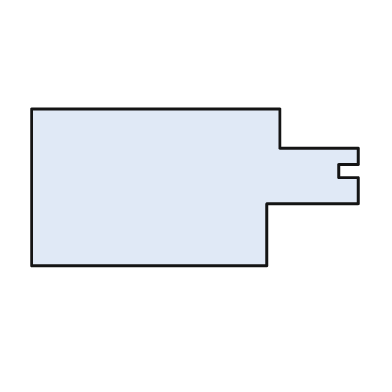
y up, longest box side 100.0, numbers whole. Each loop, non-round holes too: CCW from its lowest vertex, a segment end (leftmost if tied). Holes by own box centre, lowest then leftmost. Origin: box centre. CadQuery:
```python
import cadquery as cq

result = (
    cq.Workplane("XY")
    .moveTo(-50.0, -24.0)
    .lineTo(22.0, -24.0)
    .lineTo(22.0, -5.0)
    .lineTo(50.0, -5.0)
    .lineTo(50.0, 3.0)
    .lineTo(44.0, 3.0)
    .lineTo(44.0, 7.0)
    .lineTo(50.0, 7.0)
    .lineTo(50.0, 12.0)
    .lineTo(26.0, 12.0)
    .lineTo(26.0, 24.0)
    .lineTo(-50.0, 24.0)
    .close()
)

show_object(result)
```